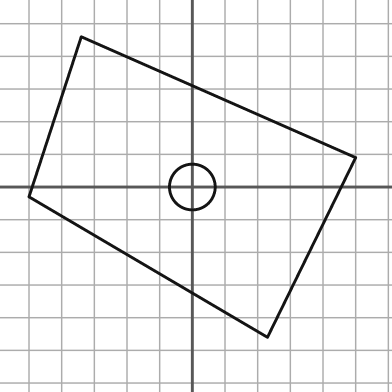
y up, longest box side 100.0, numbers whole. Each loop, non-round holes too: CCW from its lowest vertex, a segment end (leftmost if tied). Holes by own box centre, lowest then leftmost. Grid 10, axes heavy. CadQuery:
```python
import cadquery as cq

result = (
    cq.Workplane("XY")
    .moveTo(23.0, -46.0)
    .lineTo(50.0, 9.0)
    .lineTo(-34.0, 46.0)
    .lineTo(-50.0, -3.0)
    .close()
    .moveTo(0.0, 0.0)
    .circle(7.0)
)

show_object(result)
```